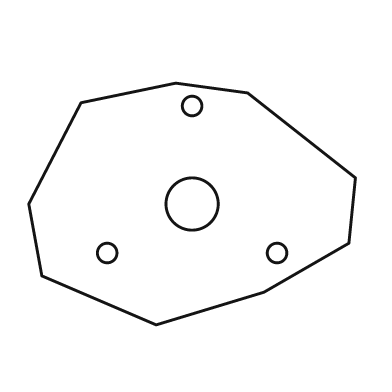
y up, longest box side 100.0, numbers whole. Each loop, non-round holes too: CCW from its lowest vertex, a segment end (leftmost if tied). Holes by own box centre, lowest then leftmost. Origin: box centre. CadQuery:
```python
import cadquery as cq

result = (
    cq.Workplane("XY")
    .moveTo(-11.0, -37.0)
    .lineTo(22.0, -27.0)
    .lineTo(48.0, -12.0)
    .lineTo(50.0, 8.0)
    .lineTo(17.0, 34.0)
    .lineTo(-5.0, 37.0)
    .lineTo(-34.0, 31.0)
    .lineTo(-50.0, 0.0)
    .lineTo(-46.0, -22.0)
    .close()
    .moveTo(-26.0, -15.0)
    .circle(3.0)
    .moveTo(26.0, -15.0)
    .circle(3.0)
    .moveTo(0.0, 0.0)
    .circle(8.0)
    .moveTo(0.0, 30.0)
    .circle(3.0)
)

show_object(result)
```